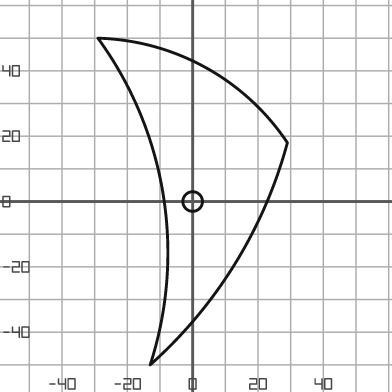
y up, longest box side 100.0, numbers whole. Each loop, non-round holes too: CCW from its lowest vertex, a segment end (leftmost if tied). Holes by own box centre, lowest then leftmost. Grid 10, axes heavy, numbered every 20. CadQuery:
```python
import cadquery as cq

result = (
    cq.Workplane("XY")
    .moveTo(-13.0, -50.0)
    .threePointArc((13.0, -19.0), (29.0, 18.0))
    .threePointArc((4.0, 41.0), (-29.0, 50.0))
    .threePointArc((-9.0, 2.0), (-13.0, -50.0))
    .close()
    .moveTo(0.0, 0.0)
    .circle(3.0)
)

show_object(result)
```